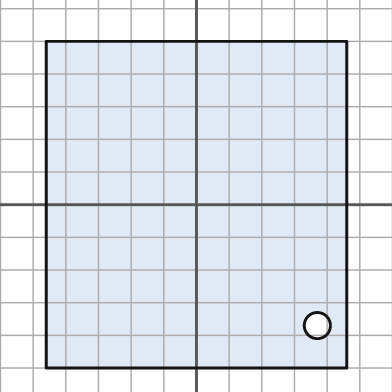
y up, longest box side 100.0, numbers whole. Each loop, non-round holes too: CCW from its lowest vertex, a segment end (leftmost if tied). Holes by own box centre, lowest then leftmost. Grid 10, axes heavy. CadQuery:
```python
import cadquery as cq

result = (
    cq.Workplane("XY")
    .moveTo(-46.0, -50.0)
    .lineTo(46.0, -50.0)
    .lineTo(46.0, 50.0)
    .lineTo(-46.0, 50.0)
    .close()
    .moveTo(37.0, -37.0)
    .circle(4.0)
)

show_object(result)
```